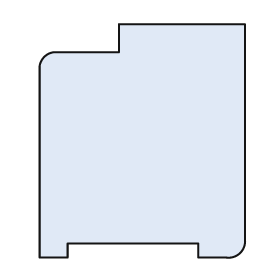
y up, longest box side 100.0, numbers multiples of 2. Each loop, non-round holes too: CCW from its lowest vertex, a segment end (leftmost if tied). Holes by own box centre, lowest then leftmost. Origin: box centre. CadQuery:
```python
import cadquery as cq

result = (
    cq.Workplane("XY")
    .moveTo(-44.0, -50.0)
    .lineTo(-32.0, -50.0)
    .lineTo(-32.0, -44.0)
    .lineTo(24.0, -44.0)
    .lineTo(24.0, -50.0)
    .lineTo(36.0, -50.0)
    .threePointArc((42.0, -48.0), (44.0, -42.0))
    .lineTo(44.0, 50.0)
    .lineTo(-10.0, 50.0)
    .lineTo(-10.0, 38.0)
    .lineTo(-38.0, 38.0)
    .threePointArc((-42.0, 36.0), (-44.0, 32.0))
    .close()
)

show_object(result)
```